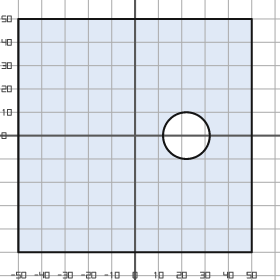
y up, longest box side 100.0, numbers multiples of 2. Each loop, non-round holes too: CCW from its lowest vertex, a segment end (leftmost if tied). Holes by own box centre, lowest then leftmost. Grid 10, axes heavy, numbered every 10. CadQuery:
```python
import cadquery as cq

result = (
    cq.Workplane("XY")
    .moveTo(-50.0, -50.0)
    .lineTo(50.0, -50.0)
    .lineTo(50.0, 50.0)
    .lineTo(-50.0, 50.0)
    .close()
    .moveTo(22.0, 0.0)
    .circle(10.0)
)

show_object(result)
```